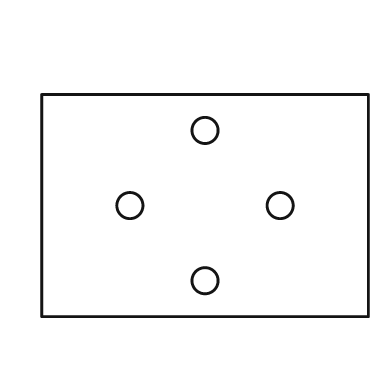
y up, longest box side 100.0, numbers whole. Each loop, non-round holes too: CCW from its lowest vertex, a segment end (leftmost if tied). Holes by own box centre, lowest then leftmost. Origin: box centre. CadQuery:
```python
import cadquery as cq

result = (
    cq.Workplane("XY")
    .moveTo(-50.0, -34.0)
    .lineTo(50.0, -34.0)
    .lineTo(50.0, 34.0)
    .lineTo(-50.0, 34.0)
    .close()
    .moveTo(0.0, -23.0)
    .circle(4.0)
    .moveTo(-23.0, 0.0)
    .circle(4.0)
    .moveTo(23.0, 0.0)
    .circle(4.0)
    .moveTo(0.0, 23.0)
    .circle(4.0)
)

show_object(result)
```